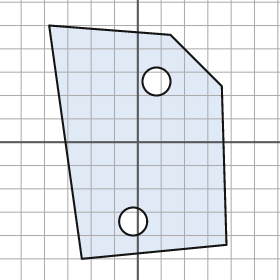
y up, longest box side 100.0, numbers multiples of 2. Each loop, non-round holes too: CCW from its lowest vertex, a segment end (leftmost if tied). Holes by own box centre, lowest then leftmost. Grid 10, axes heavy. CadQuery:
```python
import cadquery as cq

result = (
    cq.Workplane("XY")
    .moveTo(-24.0, -50.0)
    .lineTo(38.0, -44.0)
    .lineTo(36.0, 24.0)
    .lineTo(14.0, 46.0)
    .lineTo(-38.0, 50.0)
    .close()
    .moveTo(-2.0, -34.0)
    .circle(6.0)
    .moveTo(8.0, 26.0)
    .circle(6.0)
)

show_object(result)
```